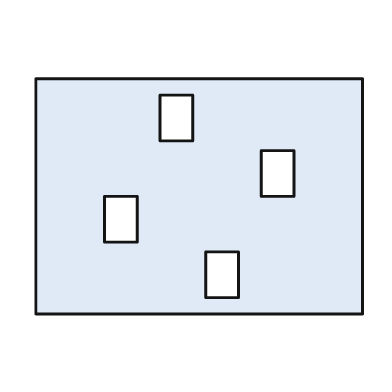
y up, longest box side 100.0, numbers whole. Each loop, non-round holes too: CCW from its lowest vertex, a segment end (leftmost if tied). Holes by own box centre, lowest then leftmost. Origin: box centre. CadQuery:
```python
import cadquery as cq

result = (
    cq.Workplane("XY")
    .moveTo(-50.0, -36.0)
    .lineTo(50.0, -36.0)
    .lineTo(50.0, 36.0)
    .lineTo(-50.0, 36.0)
    .close()
    .moveTo(2.0, -31.0)
    .lineTo(12.0, -31.0)
    .lineTo(12.0, -17.0)
    .lineTo(2.0, -17.0)
    .close()
    .moveTo(-29.0, -14.0)
    .lineTo(-19.0, -14.0)
    .lineTo(-19.0, 0.0)
    .lineTo(-29.0, 0.0)
    .close()
    .moveTo(19.0, 0.0)
    .lineTo(29.0, 0.0)
    .lineTo(29.0, 14.0)
    .lineTo(19.0, 14.0)
    .close()
    .moveTo(-12.0, 17.0)
    .lineTo(-2.0, 17.0)
    .lineTo(-2.0, 31.0)
    .lineTo(-12.0, 31.0)
    .close()
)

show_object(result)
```